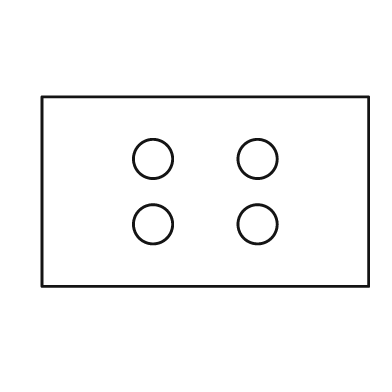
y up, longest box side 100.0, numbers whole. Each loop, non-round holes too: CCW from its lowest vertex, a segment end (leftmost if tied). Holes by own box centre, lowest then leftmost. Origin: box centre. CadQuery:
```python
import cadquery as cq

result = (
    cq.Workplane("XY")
    .moveTo(-50.0, -29.0)
    .lineTo(50.0, -29.0)
    .lineTo(50.0, 29.0)
    .lineTo(-50.0, 29.0)
    .close()
    .moveTo(-16.0, -10.0)
    .circle(6.0)
    .moveTo(16.0, -10.0)
    .circle(6.0)
    .moveTo(-16.0, 10.0)
    .circle(6.0)
    .moveTo(16.0, 10.0)
    .circle(6.0)
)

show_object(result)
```